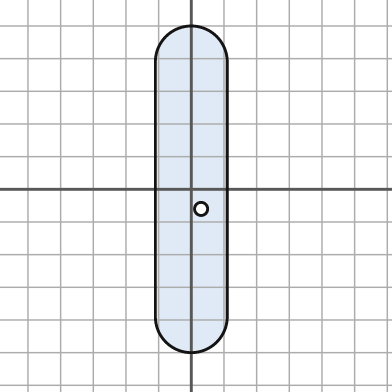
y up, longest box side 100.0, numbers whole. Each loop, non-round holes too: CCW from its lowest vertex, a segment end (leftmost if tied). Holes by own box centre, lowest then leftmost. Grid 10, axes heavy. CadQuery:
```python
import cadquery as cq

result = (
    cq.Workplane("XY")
    .moveTo(-11.0, -39.0)
    .threePointArc((0.0, -50.0), (11.0, -39.0))
    .lineTo(11.0, 39.0)
    .threePointArc((0.0, 50.0), (-11.0, 39.0))
    .close()
    .moveTo(3.0, -6.0)
    .circle(2.0)
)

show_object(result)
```